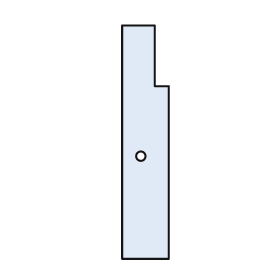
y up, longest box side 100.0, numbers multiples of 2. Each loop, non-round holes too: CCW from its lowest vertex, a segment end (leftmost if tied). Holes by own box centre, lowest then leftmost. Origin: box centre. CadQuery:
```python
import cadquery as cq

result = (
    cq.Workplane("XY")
    .moveTo(-10.0, -50.0)
    .lineTo(10.0, -50.0)
    .lineTo(10.0, 24.0)
    .lineTo(4.0, 24.0)
    .lineTo(4.0, 50.0)
    .lineTo(-10.0, 50.0)
    .close()
    .moveTo(-2.0, -6.0)
    .circle(2.0)
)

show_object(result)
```